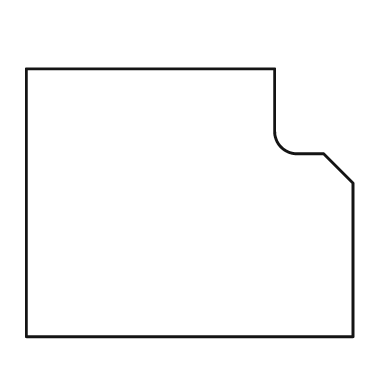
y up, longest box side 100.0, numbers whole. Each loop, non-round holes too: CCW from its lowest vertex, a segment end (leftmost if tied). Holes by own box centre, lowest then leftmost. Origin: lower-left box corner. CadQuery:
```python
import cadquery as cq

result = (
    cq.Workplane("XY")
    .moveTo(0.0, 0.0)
    .lineTo(100.0, 0.0)
    .lineTo(100.0, 47.0)
    .lineTo(91.0, 56.0)
    .lineTo(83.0, 56.0)
    .threePointArc((78.0, 58.0), (76.0, 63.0))
    .lineTo(76.0, 82.0)
    .lineTo(0.0, 82.0)
    .close()
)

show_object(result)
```